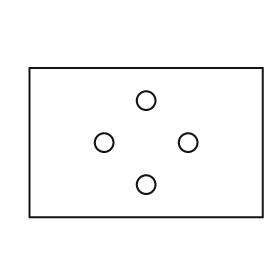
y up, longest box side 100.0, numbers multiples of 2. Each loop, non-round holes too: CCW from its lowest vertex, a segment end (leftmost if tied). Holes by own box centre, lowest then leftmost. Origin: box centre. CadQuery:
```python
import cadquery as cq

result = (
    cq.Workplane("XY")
    .moveTo(-50.0, -32.0)
    .lineTo(50.0, -32.0)
    .lineTo(50.0, 32.0)
    .lineTo(-50.0, 32.0)
    .close()
    .moveTo(0.0, -18.0)
    .circle(4.0)
    .moveTo(-18.0, 0.0)
    .circle(4.0)
    .moveTo(18.0, 0.0)
    .circle(4.0)
    .moveTo(0.0, 18.0)
    .circle(4.0)
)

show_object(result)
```